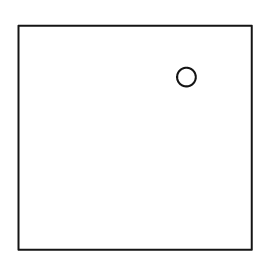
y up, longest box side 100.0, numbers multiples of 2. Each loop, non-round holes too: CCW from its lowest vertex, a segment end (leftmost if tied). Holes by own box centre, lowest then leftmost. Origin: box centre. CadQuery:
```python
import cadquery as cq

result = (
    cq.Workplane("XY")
    .moveTo(-50.0, -48.0)
    .lineTo(50.0, -48.0)
    .lineTo(50.0, 48.0)
    .lineTo(-50.0, 48.0)
    .close()
    .moveTo(22.0, 26.0)
    .circle(4.0)
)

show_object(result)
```